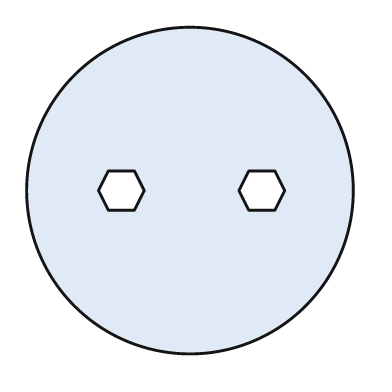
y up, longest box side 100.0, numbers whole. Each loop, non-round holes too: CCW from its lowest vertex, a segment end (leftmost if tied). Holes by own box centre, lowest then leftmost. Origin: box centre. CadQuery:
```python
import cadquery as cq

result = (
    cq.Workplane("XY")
    .moveTo(0.0, 0.0)
    .circle(50.0)
    .moveTo(-25.0, -6.0)
    .lineTo(-17.0, -6.0)
    .lineTo(-14.0, 0.0)
    .lineTo(-17.0, 6.0)
    .lineTo(-25.0, 6.0)
    .lineTo(-28.0, 0.0)
    .close()
    .moveTo(18.0, -6.0)
    .lineTo(26.0, -6.0)
    .lineTo(29.0, 0.0)
    .lineTo(26.0, 6.0)
    .lineTo(18.0, 6.0)
    .lineTo(15.0, 0.0)
    .close()
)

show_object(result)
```